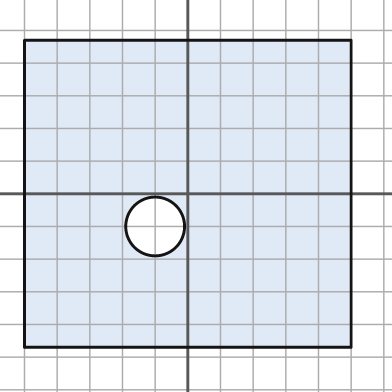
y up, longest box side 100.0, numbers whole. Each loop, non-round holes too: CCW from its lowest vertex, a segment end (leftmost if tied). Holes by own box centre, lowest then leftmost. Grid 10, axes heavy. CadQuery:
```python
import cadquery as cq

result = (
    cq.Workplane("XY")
    .moveTo(-50.0, -47.0)
    .lineTo(50.0, -47.0)
    .lineTo(50.0, 47.0)
    .lineTo(-50.0, 47.0)
    .close()
    .moveTo(-10.0, -10.0)
    .circle(9.0)
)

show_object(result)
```